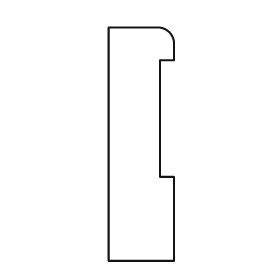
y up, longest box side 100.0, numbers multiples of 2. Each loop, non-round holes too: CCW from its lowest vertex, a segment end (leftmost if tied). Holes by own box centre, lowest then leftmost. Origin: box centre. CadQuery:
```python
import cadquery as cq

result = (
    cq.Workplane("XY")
    .moveTo(-14.0, -50.0)
    .lineTo(14.0, -50.0)
    .lineTo(14.0, -14.0)
    .lineTo(8.0, -14.0)
    .lineTo(8.0, 36.0)
    .lineTo(14.0, 36.0)
    .lineTo(14.0, 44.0)
    .threePointArc((12.0, 48.0), (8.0, 50.0))
    .lineTo(-14.0, 50.0)
    .close()
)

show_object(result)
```